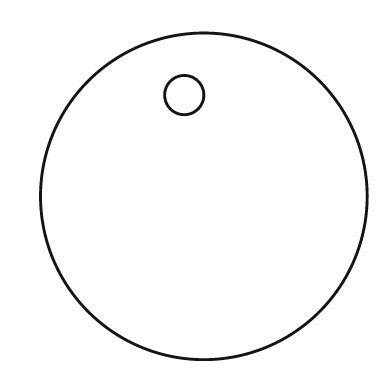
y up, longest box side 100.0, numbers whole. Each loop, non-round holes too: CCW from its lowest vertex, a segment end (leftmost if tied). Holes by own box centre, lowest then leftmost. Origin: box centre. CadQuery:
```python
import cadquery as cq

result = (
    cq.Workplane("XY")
    .moveTo(0.0, 0.0)
    .circle(50.0)
    .moveTo(-6.0, 31.0)
    .circle(6.0)
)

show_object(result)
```